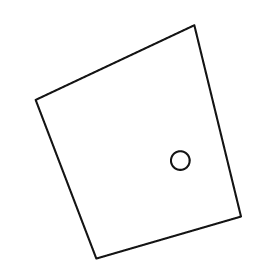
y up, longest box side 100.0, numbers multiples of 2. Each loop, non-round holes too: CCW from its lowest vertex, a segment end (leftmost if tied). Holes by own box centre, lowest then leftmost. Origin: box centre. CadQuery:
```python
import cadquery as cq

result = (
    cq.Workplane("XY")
    .moveTo(-18.0, -50.0)
    .lineTo(44.0, -32.0)
    .lineTo(24.0, 50.0)
    .lineTo(-44.0, 18.0)
    .close()
    .moveTo(18.0, -8.0)
    .circle(4.0)
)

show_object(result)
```